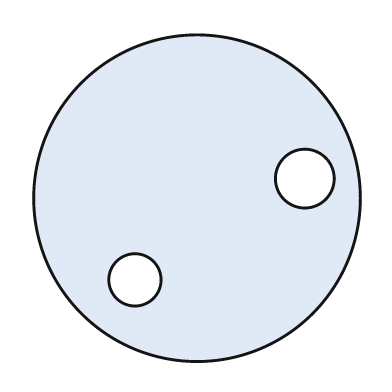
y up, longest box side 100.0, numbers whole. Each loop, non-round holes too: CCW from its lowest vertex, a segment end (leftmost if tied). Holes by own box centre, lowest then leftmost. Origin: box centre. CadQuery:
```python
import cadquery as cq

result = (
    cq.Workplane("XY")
    .moveTo(0.0, 0.0)
    .circle(50.0)
    .moveTo(-19.0, -25.0)
    .circle(8.0)
    .moveTo(33.0, 6.0)
    .circle(9.0)
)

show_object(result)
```